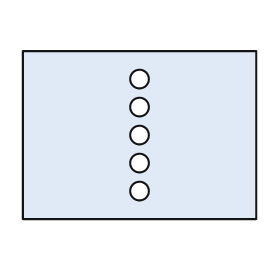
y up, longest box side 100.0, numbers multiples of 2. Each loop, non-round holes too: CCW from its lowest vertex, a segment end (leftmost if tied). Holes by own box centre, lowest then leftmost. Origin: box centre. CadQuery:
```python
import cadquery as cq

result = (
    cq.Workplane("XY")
    .moveTo(-50.0, -36.0)
    .lineTo(50.0, -36.0)
    .lineTo(50.0, 36.0)
    .lineTo(-50.0, 36.0)
    .close()
    .moveTo(0.0, -24.0)
    .circle(4.0)
    .moveTo(0.0, -12.0)
    .circle(4.0)
    .moveTo(0.0, 0.0)
    .circle(4.0)
    .moveTo(0.0, 12.0)
    .circle(4.0)
    .moveTo(0.0, 24.0)
    .circle(4.0)
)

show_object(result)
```